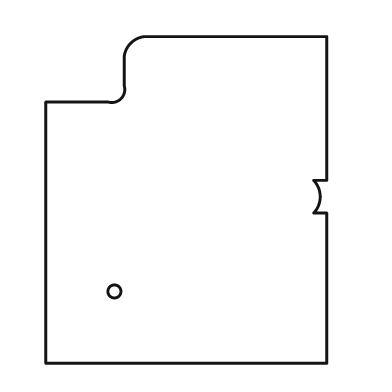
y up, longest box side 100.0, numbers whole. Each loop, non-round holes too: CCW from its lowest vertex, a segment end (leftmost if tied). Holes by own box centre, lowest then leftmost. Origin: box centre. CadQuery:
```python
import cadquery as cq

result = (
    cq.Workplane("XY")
    .moveTo(-43.0, -50.0)
    .lineTo(43.0, -50.0)
    .lineTo(43.0, -4.0)
    .lineTo(39.0, -4.0)
    .threePointArc((41.0, 1.0), (39.0, 6.0))
    .lineTo(43.0, 6.0)
    .lineTo(43.0, 50.0)
    .lineTo(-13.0, 50.0)
    .threePointArc((-17.0, 48.0), (-19.0, 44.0))
    .lineTo(-19.0, 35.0)
    .threePointArc((-20.0, 31.0), (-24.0, 30.0))
    .lineTo(-43.0, 30.0)
    .close()
    .moveTo(-22.0, -28.0)
    .circle(2.0)
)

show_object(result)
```